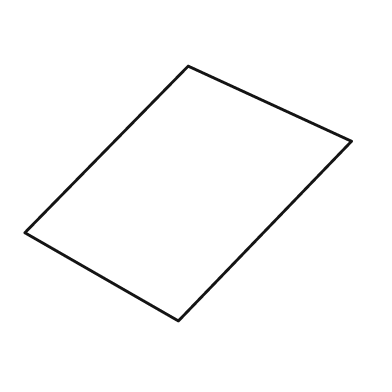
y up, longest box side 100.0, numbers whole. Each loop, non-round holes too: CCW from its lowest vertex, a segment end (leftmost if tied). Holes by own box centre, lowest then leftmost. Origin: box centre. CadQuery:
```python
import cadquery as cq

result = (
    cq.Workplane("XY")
    .moveTo(-3.0, -39.0)
    .lineTo(50.0, 16.0)
    .lineTo(0.0, 39.0)
    .lineTo(-50.0, -12.0)
    .close()
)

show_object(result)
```